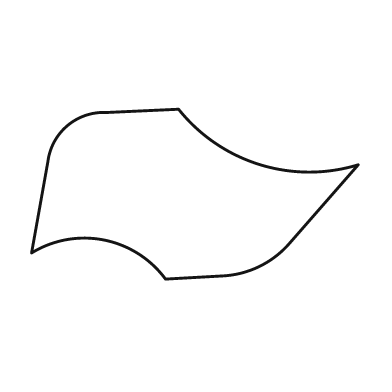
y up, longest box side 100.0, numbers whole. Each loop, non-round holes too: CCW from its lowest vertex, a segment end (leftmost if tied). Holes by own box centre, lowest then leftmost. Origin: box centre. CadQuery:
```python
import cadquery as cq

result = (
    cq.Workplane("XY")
    .moveTo(-9.0, -26.0)
    .lineTo(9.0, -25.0)
    .threePointArc((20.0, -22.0), (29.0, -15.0))
    .lineTo(50.0, 9.0)
    .threePointArc((20.0, 9.0), (-5.0, 26.0))
    .lineTo(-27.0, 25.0)
    .threePointArc((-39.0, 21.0), (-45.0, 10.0))
    .lineTo(-50.0, -18.0)
    .threePointArc((-28.0, -14.0), (-9.0, -26.0))
    .close()
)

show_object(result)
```